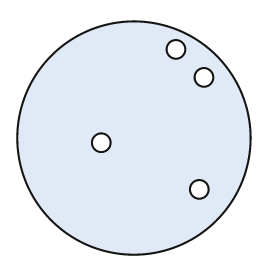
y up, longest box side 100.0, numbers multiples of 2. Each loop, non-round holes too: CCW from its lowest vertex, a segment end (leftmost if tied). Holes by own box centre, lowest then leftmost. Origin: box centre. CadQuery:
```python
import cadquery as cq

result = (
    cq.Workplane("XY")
    .moveTo(0.0, 0.0)
    .circle(50.0)
    .moveTo(28.0, -22.0)
    .circle(4.0)
    .moveTo(-14.0, -2.0)
    .circle(4.0)
    .moveTo(30.0, 26.0)
    .circle(4.0)
    .moveTo(18.0, 38.0)
    .circle(4.0)
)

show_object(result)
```